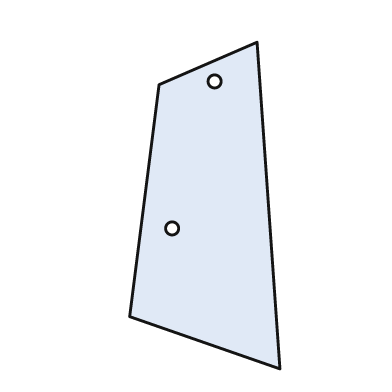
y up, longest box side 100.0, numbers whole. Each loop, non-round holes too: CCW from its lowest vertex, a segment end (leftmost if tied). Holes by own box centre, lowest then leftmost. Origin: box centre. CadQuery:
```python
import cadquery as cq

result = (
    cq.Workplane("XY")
    .moveTo(23.0, -50.0)
    .lineTo(16.0, 50.0)
    .lineTo(-14.0, 37.0)
    .lineTo(-23.0, -34.0)
    .close()
    .moveTo(-10.0, -7.0)
    .circle(2.0)
    .moveTo(3.0, 38.0)
    .circle(2.0)
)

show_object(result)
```